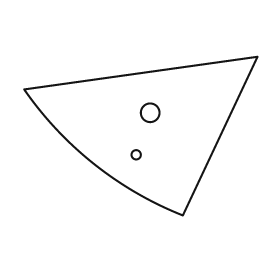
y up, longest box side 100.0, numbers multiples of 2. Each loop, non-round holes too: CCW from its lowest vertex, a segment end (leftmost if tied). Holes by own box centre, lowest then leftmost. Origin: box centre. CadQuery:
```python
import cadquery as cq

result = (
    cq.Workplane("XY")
    .moveTo(18.0, -34.0)
    .lineTo(50.0, 34.0)
    .lineTo(-50.0, 20.0)
    .threePointArc((-20.0, -12.0), (18.0, -34.0))
    .close()
    .moveTo(-2.0, -8.0)
    .circle(2.0)
    .moveTo(4.0, 10.0)
    .circle(4.0)
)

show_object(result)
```